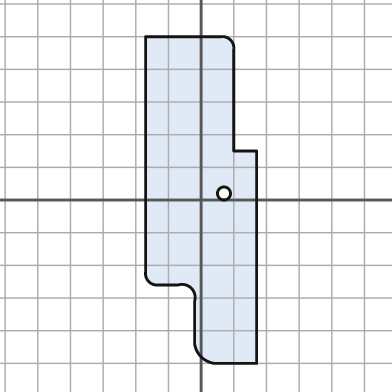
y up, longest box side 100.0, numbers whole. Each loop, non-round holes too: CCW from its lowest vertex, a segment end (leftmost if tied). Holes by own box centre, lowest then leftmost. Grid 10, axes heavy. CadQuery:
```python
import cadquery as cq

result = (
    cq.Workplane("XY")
    .moveTo(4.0, -50.0)
    .lineTo(17.0, -50.0)
    .lineTo(17.0, 15.0)
    .lineTo(10.0, 15.0)
    .lineTo(10.0, 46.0)
    .threePointArc((9.0, 49.0), (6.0, 50.0))
    .lineTo(-17.0, 50.0)
    .lineTo(-17.0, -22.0)
    .threePointArc((-16.0, -25.0), (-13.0, -26.0))
    .lineTo(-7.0, -26.0)
    .threePointArc((-3.0, -27.0), (-2.0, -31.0))
    .lineTo(-2.0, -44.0)
    .threePointArc((0.0, -48.0), (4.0, -50.0))
    .close()
    .moveTo(7.0, 2.0)
    .circle(2.0)
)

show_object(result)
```